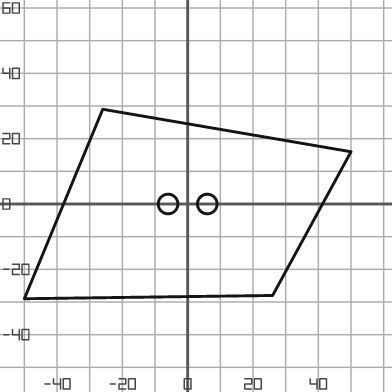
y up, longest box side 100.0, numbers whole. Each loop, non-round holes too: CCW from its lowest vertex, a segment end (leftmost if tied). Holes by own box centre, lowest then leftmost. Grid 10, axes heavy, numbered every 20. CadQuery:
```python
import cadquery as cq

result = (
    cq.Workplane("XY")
    .moveTo(-50.0, -29.0)
    .lineTo(26.0, -28.0)
    .lineTo(50.0, 16.0)
    .lineTo(-26.0, 29.0)
    .close()
    .moveTo(-6.0, 0.0)
    .circle(3.0)
    .moveTo(6.0, 0.0)
    .circle(3.0)
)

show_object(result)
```